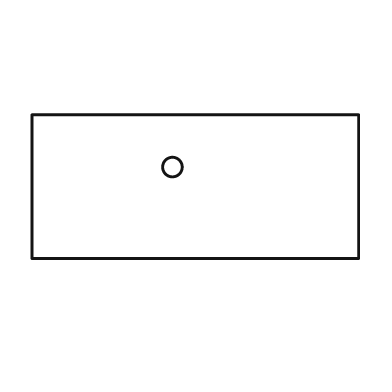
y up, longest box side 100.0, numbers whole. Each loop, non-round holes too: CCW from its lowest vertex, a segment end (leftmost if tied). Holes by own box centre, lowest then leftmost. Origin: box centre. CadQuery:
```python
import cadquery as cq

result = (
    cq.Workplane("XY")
    .moveTo(-50.0, -22.0)
    .lineTo(50.0, -22.0)
    .lineTo(50.0, 22.0)
    .lineTo(-50.0, 22.0)
    .close()
    .moveTo(-7.0, 6.0)
    .circle(3.0)
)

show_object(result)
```